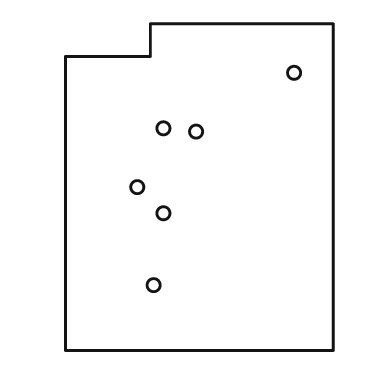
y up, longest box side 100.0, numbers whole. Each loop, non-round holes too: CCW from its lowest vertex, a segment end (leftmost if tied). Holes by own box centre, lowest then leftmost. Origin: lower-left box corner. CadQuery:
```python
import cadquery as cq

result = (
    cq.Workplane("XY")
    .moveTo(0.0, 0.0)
    .lineTo(82.0, 0.0)
    .lineTo(82.0, 100.0)
    .lineTo(26.0, 100.0)
    .lineTo(26.0, 90.0)
    .lineTo(0.0, 90.0)
    .close()
    .moveTo(27.0, 20.0)
    .circle(2.0)
    .moveTo(30.0, 42.0)
    .circle(2.0)
    .moveTo(22.0, 50.0)
    .circle(2.0)
    .moveTo(40.0, 67.0)
    .circle(2.0)
    .moveTo(30.0, 68.0)
    .circle(2.0)
    .moveTo(70.0, 85.0)
    .circle(2.0)
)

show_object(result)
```